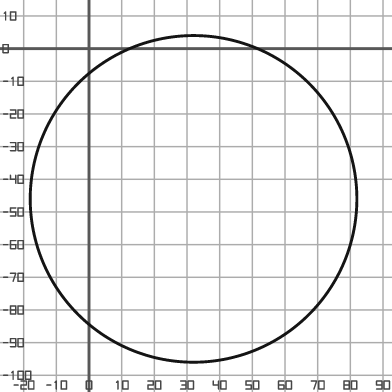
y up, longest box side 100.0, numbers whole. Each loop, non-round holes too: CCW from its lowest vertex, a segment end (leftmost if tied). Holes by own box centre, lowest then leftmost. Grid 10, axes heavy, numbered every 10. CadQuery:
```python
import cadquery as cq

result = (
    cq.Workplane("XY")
    .moveTo(32.0, -46.0)
    .circle(50.0)
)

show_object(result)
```